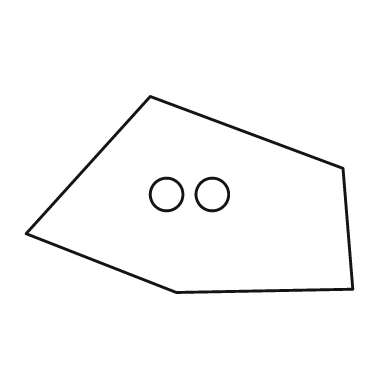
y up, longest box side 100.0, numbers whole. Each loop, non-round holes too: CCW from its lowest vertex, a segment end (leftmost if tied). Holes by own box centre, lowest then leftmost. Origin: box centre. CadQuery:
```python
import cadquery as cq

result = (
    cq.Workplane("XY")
    .moveTo(-4.0, -30.0)
    .lineTo(50.0, -29.0)
    .lineTo(47.0, 8.0)
    .lineTo(-12.0, 30.0)
    .lineTo(-50.0, -12.0)
    .close()
    .moveTo(-7.0, 0.0)
    .circle(5.0)
    .moveTo(7.0, 0.0)
    .circle(5.0)
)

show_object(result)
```